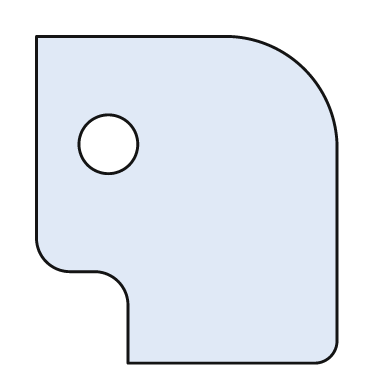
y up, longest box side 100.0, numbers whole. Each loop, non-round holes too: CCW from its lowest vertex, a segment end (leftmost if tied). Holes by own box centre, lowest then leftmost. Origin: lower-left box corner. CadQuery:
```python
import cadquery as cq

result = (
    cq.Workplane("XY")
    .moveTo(28.0, 0.0)
    .lineTo(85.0, 0.0)
    .threePointArc((90.0, 2.0), (92.0, 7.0))
    .lineTo(92.0, 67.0)
    .threePointArc((82.0, 90.0), (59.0, 100.0))
    .lineTo(0.0, 100.0)
    .lineTo(0.0, 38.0)
    .threePointArc((3.0, 31.0), (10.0, 28.0))
    .lineTo(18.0, 28.0)
    .threePointArc((25.0, 25.0), (28.0, 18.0))
    .close()
    .moveTo(22.0, 67.0)
    .circle(9.0)
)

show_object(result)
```